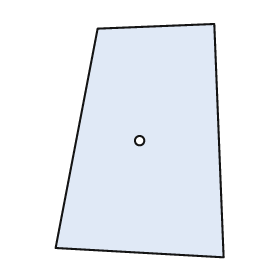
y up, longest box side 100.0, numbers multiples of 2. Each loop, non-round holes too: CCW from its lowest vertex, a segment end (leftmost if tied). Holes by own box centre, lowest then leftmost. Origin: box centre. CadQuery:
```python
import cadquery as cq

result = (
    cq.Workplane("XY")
    .moveTo(36.0, -50.0)
    .lineTo(32.0, 50.0)
    .lineTo(-18.0, 48.0)
    .lineTo(-36.0, -46.0)
    .close()
    .moveTo(0.0, 0.0)
    .circle(2.0)
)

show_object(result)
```